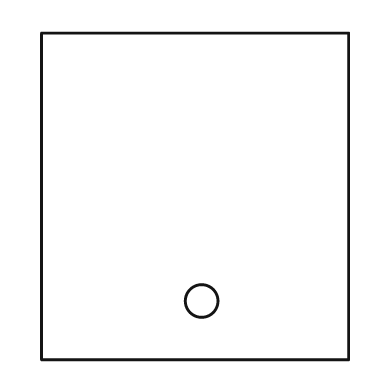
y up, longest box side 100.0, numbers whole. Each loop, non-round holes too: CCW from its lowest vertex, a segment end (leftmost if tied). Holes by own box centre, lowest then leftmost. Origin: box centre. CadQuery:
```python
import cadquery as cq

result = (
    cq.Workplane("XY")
    .moveTo(-47.0, -50.0)
    .lineTo(47.0, -50.0)
    .lineTo(47.0, 50.0)
    .lineTo(-47.0, 50.0)
    .close()
    .moveTo(2.0, -32.0)
    .circle(5.0)
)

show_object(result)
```